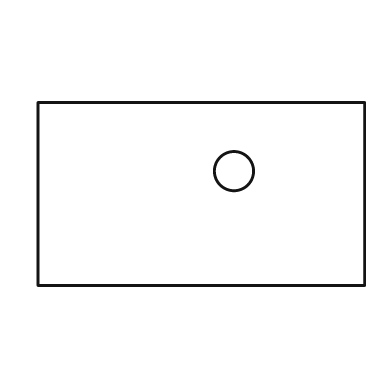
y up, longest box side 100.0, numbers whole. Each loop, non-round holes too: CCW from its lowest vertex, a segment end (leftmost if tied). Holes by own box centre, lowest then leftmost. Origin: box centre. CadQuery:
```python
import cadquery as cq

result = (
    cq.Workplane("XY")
    .moveTo(-50.0, -28.0)
    .lineTo(50.0, -28.0)
    .lineTo(50.0, 28.0)
    .lineTo(-50.0, 28.0)
    .close()
    .moveTo(10.0, 7.0)
    .circle(6.0)
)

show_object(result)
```